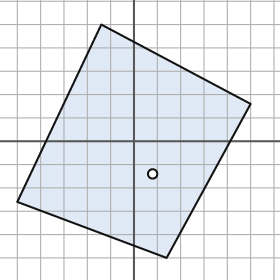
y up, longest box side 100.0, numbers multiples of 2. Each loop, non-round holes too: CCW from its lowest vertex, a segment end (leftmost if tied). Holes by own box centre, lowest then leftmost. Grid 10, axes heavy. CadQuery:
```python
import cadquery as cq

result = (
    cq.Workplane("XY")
    .moveTo(14.0, -50.0)
    .lineTo(50.0, 16.0)
    .lineTo(-14.0, 50.0)
    .lineTo(-50.0, -26.0)
    .close()
    .moveTo(8.0, -14.0)
    .circle(2.0)
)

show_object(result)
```